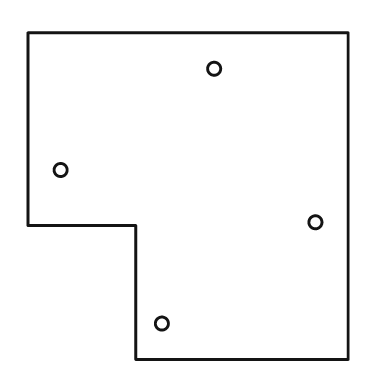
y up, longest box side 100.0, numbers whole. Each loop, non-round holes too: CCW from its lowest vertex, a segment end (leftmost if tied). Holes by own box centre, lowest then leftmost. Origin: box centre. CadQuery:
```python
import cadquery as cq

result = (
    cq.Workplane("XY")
    .moveTo(-16.0, -50.0)
    .lineTo(49.0, -50.0)
    .lineTo(49.0, 50.0)
    .lineTo(-49.0, 50.0)
    .lineTo(-49.0, -9.0)
    .lineTo(-16.0, -9.0)
    .close()
    .moveTo(-8.0, -39.0)
    .circle(2.0)
    .moveTo(39.0, -8.0)
    .circle(2.0)
    .moveTo(-39.0, 8.0)
    .circle(2.0)
    .moveTo(8.0, 39.0)
    .circle(2.0)
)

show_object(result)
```